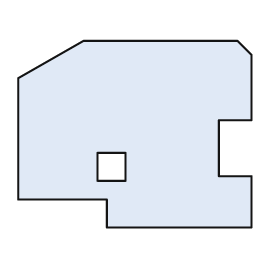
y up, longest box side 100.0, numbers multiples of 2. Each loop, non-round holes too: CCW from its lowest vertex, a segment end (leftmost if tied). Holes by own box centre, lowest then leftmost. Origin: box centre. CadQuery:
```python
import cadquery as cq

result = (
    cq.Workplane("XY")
    .moveTo(-12.0, -40.0)
    .lineTo(50.0, -40.0)
    .lineTo(50.0, -18.0)
    .lineTo(36.0, -18.0)
    .lineTo(36.0, 6.0)
    .lineTo(50.0, 6.0)
    .lineTo(50.0, 34.0)
    .lineTo(44.0, 40.0)
    .lineTo(-22.0, 40.0)
    .lineTo(-50.0, 24.0)
    .lineTo(-50.0, -28.0)
    .lineTo(-12.0, -28.0)
    .close()
    .moveTo(-16.0, -20.0)
    .lineTo(-4.0, -20.0)
    .lineTo(-4.0, -8.0)
    .lineTo(-16.0, -8.0)
    .close()
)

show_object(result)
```